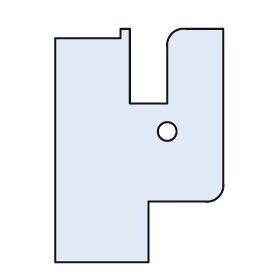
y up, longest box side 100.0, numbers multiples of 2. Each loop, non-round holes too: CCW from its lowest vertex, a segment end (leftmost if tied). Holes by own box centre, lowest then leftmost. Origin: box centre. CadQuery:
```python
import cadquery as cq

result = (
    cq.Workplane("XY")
    .moveTo(-36.0, -50.0)
    .lineTo(4.0, -50.0)
    .lineTo(4.0, -24.0)
    .lineTo(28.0, -24.0)
    .threePointArc((34.0, -22.0), (36.0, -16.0))
    .lineTo(36.0, 50.0)
    .lineTo(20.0, 50.0)
    .threePointArc((14.0, 48.0), (12.0, 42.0))
    .lineTo(12.0, 18.0)
    .lineTo(-4.0, 18.0)
    .lineTo(-4.0, 50.0)
    .lineTo(-8.0, 50.0)
    .lineTo(-8.0, 46.0)
    .lineTo(-36.0, 46.0)
    .close()
    .moveTo(12.0, 6.0)
    .circle(4.0)
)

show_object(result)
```